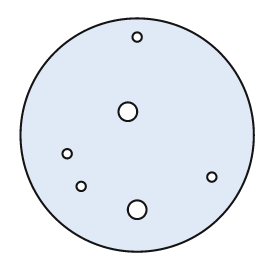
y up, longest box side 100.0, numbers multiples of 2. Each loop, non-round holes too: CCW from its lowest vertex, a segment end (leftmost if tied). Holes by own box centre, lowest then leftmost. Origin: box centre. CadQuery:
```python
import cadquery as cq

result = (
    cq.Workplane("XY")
    .moveTo(0.0, 0.0)
    .circle(50.0)
    .moveTo(0.0, -32.0)
    .circle(4.0)
    .moveTo(-24.0, -22.0)
    .circle(2.0)
    .moveTo(32.0, -18.0)
    .circle(2.0)
    .moveTo(-30.0, -8.0)
    .circle(2.0)
    .moveTo(-4.0, 10.0)
    .circle(4.0)
    .moveTo(0.0, 42.0)
    .circle(2.0)
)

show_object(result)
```